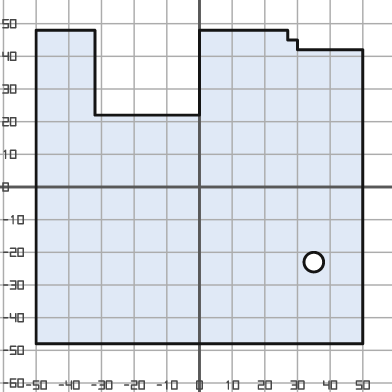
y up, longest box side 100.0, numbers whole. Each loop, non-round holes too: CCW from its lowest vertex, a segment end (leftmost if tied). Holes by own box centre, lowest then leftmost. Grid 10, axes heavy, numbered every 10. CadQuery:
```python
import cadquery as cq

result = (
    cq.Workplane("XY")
    .moveTo(-50.0, -48.0)
    .lineTo(50.0, -48.0)
    .lineTo(50.0, 42.0)
    .lineTo(30.0, 42.0)
    .lineTo(30.0, 45.0)
    .lineTo(27.0, 45.0)
    .lineTo(27.0, 48.0)
    .lineTo(0.0, 48.0)
    .lineTo(0.0, 22.0)
    .lineTo(-32.0, 22.0)
    .lineTo(-32.0, 48.0)
    .lineTo(-50.0, 48.0)
    .close()
    .moveTo(35.0, -23.0)
    .circle(3.0)
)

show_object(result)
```